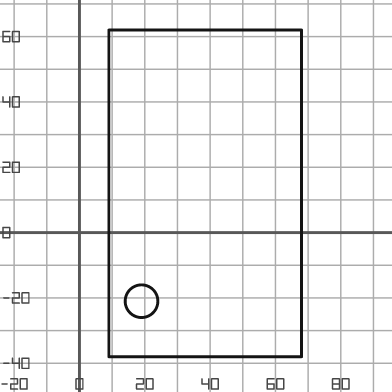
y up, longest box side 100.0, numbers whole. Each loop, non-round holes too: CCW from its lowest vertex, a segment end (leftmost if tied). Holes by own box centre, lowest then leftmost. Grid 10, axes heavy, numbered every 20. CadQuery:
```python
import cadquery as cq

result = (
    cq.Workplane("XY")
    .moveTo(9.0, -38.0)
    .lineTo(68.0, -38.0)
    .lineTo(68.0, 62.0)
    .lineTo(9.0, 62.0)
    .close()
    .moveTo(19.0, -21.0)
    .circle(5.0)
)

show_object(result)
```